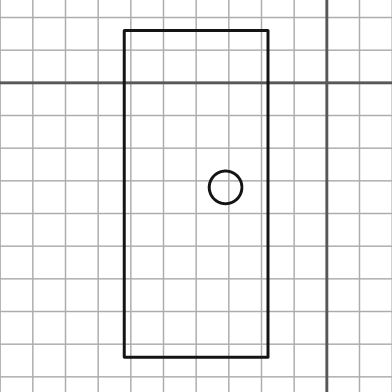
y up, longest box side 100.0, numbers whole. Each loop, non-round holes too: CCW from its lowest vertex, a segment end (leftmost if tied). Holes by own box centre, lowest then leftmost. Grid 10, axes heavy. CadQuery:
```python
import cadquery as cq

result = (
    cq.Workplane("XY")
    .moveTo(-62.0, -84.0)
    .lineTo(-18.0, -84.0)
    .lineTo(-18.0, 16.0)
    .lineTo(-62.0, 16.0)
    .close()
    .moveTo(-31.0, -32.0)
    .circle(5.0)
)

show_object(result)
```